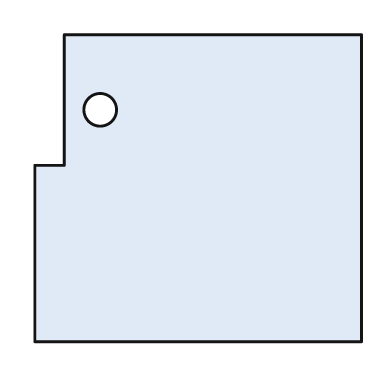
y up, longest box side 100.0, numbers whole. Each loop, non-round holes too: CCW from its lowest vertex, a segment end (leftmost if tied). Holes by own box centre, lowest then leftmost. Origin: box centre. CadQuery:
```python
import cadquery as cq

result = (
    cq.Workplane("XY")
    .moveTo(-50.0, -47.0)
    .lineTo(50.0, -47.0)
    .lineTo(50.0, 47.0)
    .lineTo(-41.0, 47.0)
    .lineTo(-41.0, 7.0)
    .lineTo(-50.0, 7.0)
    .close()
    .moveTo(-30.0, 24.0)
    .circle(5.0)
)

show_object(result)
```